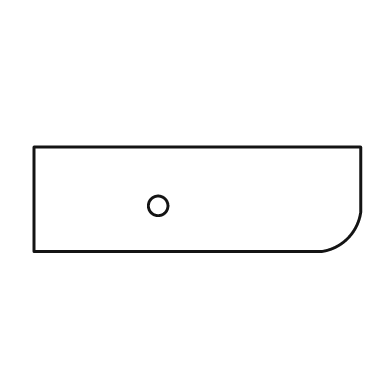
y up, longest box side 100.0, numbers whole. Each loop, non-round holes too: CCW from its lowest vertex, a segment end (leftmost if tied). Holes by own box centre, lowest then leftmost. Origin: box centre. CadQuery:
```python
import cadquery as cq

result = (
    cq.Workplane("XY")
    .moveTo(-50.0, -16.0)
    .lineTo(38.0, -16.0)
    .threePointArc((46.0, -12.0), (50.0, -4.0))
    .lineTo(50.0, 16.0)
    .lineTo(-50.0, 16.0)
    .close()
    .moveTo(-12.0, -2.0)
    .circle(3.0)
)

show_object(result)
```